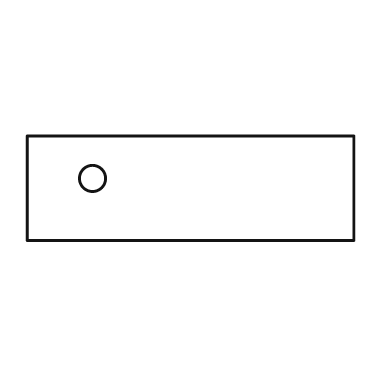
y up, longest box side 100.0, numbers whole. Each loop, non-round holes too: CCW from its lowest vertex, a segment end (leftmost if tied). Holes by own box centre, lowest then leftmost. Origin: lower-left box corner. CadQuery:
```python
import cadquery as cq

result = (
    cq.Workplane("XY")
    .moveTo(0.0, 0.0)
    .lineTo(100.0, 0.0)
    .lineTo(100.0, 32.0)
    .lineTo(0.0, 32.0)
    .close()
    .moveTo(20.0, 19.0)
    .circle(4.0)
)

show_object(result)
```